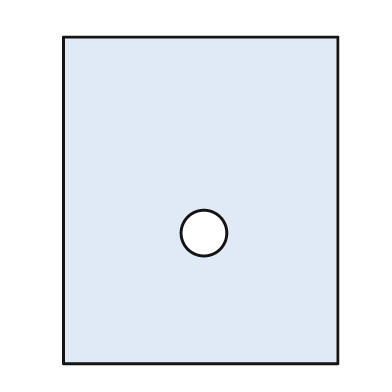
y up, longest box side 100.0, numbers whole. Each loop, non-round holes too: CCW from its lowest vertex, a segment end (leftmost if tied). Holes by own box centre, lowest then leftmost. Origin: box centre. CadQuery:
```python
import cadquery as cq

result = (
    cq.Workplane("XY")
    .moveTo(-42.0, -50.0)
    .lineTo(42.0, -50.0)
    .lineTo(42.0, 50.0)
    .lineTo(-42.0, 50.0)
    .close()
    .moveTo(1.0, -10.0)
    .circle(7.0)
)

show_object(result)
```